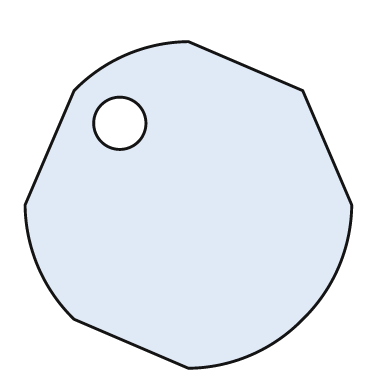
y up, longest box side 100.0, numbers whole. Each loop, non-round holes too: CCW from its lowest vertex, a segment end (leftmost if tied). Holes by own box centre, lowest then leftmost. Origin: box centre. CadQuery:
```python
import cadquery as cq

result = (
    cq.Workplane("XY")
    .moveTo(0.0, -50.0)
    .threePointArc((19.0, -46.0), (35.0, -35.0))
    .threePointArc((46.0, -19.0), (50.0, 0.0))
    .lineTo(35.0, 35.0)
    .lineTo(0.0, 50.0)
    .threePointArc((-19.0, 46.0), (-35.0, 35.0))
    .lineTo(-50.0, 0.0)
    .threePointArc((-46.0, -19.0), (-35.0, -35.0))
    .close()
    .moveTo(-21.0, 25.0)
    .circle(8.0)
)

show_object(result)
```